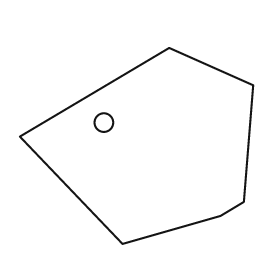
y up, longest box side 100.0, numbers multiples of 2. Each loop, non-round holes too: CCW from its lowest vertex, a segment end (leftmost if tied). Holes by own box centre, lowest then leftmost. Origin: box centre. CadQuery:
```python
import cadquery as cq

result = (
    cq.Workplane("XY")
    .moveTo(-6.0, -42.0)
    .lineTo(36.0, -30.0)
    .lineTo(46.0, -24.0)
    .lineTo(50.0, 26.0)
    .lineTo(14.0, 42.0)
    .lineTo(-50.0, 4.0)
    .close()
    .moveTo(-14.0, 10.0)
    .circle(4.0)
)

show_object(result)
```